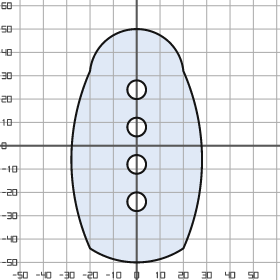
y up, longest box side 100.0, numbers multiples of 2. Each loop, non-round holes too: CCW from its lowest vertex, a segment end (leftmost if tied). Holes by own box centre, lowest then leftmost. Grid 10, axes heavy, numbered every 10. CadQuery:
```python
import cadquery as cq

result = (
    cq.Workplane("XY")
    .moveTo(-20.0, -44.0)
    .threePointArc((0.0, -50.0), (20.0, -44.0))
    .threePointArc((28.0, -6.0), (20.0, 32.0))
    .threePointArc((0.0, 50.0), (-20.0, 32.0))
    .threePointArc((-28.0, -6.0), (-20.0, -44.0))
    .close()
    .moveTo(0.0, -24.0)
    .circle(4.0)
    .moveTo(0.0, -8.0)
    .circle(4.0)
    .moveTo(0.0, 8.0)
    .circle(4.0)
    .moveTo(0.0, 24.0)
    .circle(4.0)
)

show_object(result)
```